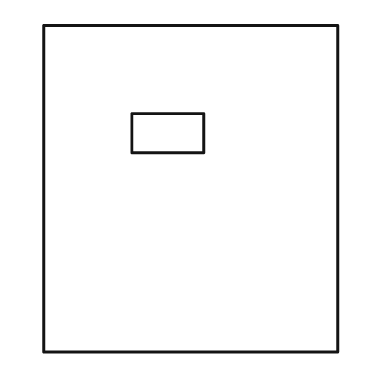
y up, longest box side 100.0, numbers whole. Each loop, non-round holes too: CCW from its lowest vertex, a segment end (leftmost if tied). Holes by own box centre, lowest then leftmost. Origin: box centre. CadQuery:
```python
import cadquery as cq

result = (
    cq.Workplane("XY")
    .moveTo(-45.0, -50.0)
    .lineTo(45.0, -50.0)
    .lineTo(45.0, 50.0)
    .lineTo(-45.0, 50.0)
    .close()
    .moveTo(-18.0, 11.0)
    .lineTo(4.0, 11.0)
    .lineTo(4.0, 23.0)
    .lineTo(-18.0, 23.0)
    .close()
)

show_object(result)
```